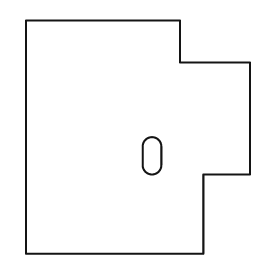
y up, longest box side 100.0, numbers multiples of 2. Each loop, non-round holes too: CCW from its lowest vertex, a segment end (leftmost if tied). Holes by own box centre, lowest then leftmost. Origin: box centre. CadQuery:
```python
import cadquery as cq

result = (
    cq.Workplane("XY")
    .moveTo(-48.0, -50.0)
    .lineTo(28.0, -50.0)
    .lineTo(28.0, -16.0)
    .lineTo(48.0, -16.0)
    .lineTo(48.0, 32.0)
    .lineTo(18.0, 32.0)
    .lineTo(18.0, 50.0)
    .lineTo(-48.0, 50.0)
    .close()
    .moveTo(2.0, -12.0)
    .threePointArc((6.0, -16.0), (10.0, -12.0))
    .lineTo(10.0, -4.0)
    .threePointArc((6.0, 0.0), (2.0, -4.0))
    .close()
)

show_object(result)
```